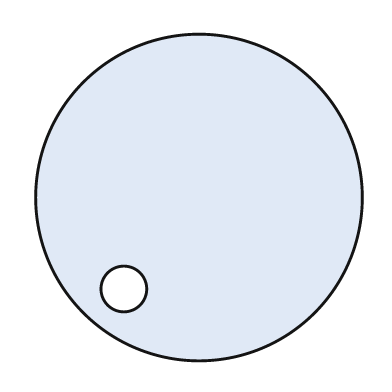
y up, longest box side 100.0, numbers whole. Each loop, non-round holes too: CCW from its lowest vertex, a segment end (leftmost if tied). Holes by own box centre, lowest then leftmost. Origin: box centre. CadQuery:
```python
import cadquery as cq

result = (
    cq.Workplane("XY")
    .moveTo(0.0, 0.0)
    .circle(50.0)
    .moveTo(-23.0, -28.0)
    .circle(7.0)
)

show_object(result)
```